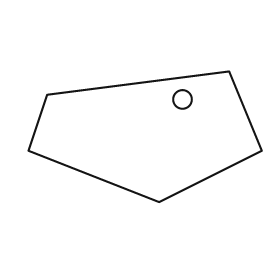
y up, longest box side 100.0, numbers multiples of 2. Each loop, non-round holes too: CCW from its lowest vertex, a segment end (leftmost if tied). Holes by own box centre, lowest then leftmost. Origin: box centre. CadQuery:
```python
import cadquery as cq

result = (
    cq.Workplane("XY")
    .moveTo(6.0, -28.0)
    .lineTo(50.0, -6.0)
    .lineTo(36.0, 28.0)
    .lineTo(-42.0, 18.0)
    .lineTo(-50.0, -6.0)
    .close()
    .moveTo(16.0, 16.0)
    .circle(4.0)
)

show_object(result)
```